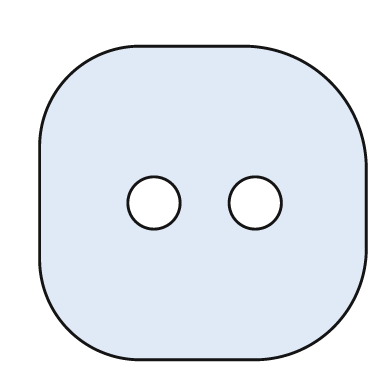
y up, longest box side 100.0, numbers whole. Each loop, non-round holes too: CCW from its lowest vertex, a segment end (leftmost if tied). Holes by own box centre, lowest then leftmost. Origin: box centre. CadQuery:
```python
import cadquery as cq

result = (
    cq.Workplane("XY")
    .moveTo(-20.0, -48.0)
    .lineTo(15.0, -48.0)
    .threePointArc((40.0, -38.0), (50.0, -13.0))
    .lineTo(50.0, 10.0)
    .threePointArc((39.0, 37.0), (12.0, 48.0))
    .lineTo(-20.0, 48.0)
    .threePointArc((-41.0, 39.0), (-50.0, 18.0))
    .lineTo(-50.0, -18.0)
    .threePointArc((-41.0, -39.0), (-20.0, -48.0))
    .close()
    .moveTo(-15.0, 0.0)
    .circle(8.0)
    .moveTo(16.0, 0.0)
    .circle(8.0)
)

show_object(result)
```